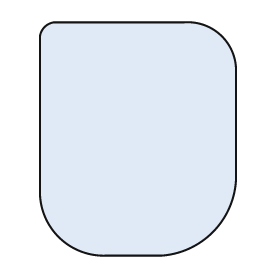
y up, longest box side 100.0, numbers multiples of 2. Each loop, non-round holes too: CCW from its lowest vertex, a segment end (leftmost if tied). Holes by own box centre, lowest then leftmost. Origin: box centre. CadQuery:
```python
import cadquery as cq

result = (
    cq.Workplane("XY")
    .moveTo(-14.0, -50.0)
    .lineTo(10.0, -50.0)
    .threePointArc((32.0, -40.0), (42.0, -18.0))
    .lineTo(42.0, 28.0)
    .threePointArc((36.0, 44.0), (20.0, 50.0))
    .lineTo(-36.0, 50.0)
    .threePointArc((-40.0, 48.0), (-42.0, 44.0))
    .lineTo(-42.0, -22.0)
    .threePointArc((-34.0, -42.0), (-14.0, -50.0))
    .close()
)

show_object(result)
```